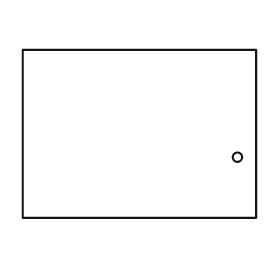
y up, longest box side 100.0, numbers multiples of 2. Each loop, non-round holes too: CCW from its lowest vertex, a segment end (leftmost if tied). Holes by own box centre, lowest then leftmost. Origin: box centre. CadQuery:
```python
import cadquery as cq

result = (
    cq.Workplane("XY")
    .moveTo(-50.0, -36.0)
    .lineTo(50.0, -36.0)
    .lineTo(50.0, 36.0)
    .lineTo(-50.0, 36.0)
    .close()
    .moveTo(42.0, -10.0)
    .circle(2.0)
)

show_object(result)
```